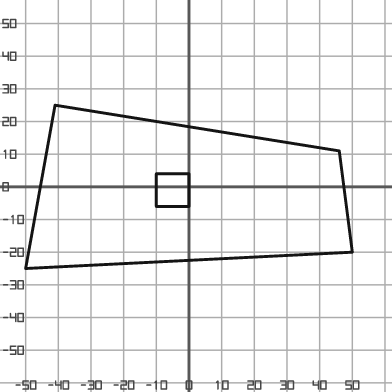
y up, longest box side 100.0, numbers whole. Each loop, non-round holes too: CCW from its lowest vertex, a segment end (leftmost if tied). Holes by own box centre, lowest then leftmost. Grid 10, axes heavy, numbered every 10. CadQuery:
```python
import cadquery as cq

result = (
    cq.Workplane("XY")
    .moveTo(-50.0, -25.0)
    .lineTo(50.0, -20.0)
    .lineTo(46.0, 11.0)
    .lineTo(-41.0, 25.0)
    .close()
    .moveTo(-10.0, -6.0)
    .lineTo(0.0, -6.0)
    .lineTo(0.0, 4.0)
    .lineTo(-10.0, 4.0)
    .close()
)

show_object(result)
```